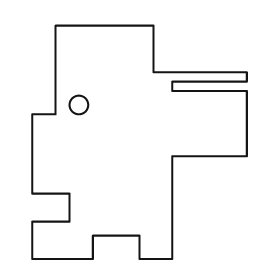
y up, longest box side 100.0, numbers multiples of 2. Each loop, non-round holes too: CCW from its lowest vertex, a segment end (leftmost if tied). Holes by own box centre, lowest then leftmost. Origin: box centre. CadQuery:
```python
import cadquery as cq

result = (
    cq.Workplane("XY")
    .moveTo(-46.0, -50.0)
    .lineTo(-20.0, -50.0)
    .lineTo(-20.0, -40.0)
    .lineTo(0.0, -40.0)
    .lineTo(0.0, -50.0)
    .lineTo(14.0, -50.0)
    .lineTo(14.0, -6.0)
    .lineTo(46.0, -6.0)
    .lineTo(46.0, 22.0)
    .lineTo(14.0, 22.0)
    .lineTo(14.0, 26.0)
    .lineTo(46.0, 26.0)
    .lineTo(46.0, 30.0)
    .lineTo(6.0, 30.0)
    .lineTo(6.0, 50.0)
    .lineTo(-36.0, 50.0)
    .lineTo(-36.0, 12.0)
    .lineTo(-46.0, 12.0)
    .lineTo(-46.0, -22.0)
    .lineTo(-30.0, -22.0)
    .lineTo(-30.0, -34.0)
    .lineTo(-46.0, -34.0)
    .close()
    .moveTo(-26.0, 16.0)
    .circle(4.0)
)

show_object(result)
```